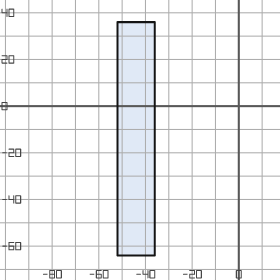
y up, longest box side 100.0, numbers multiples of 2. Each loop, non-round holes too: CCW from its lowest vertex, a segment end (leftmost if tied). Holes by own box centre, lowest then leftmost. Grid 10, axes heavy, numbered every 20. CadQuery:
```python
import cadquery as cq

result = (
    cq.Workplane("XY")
    .moveTo(-52.0, -64.0)
    .lineTo(-36.0, -64.0)
    .lineTo(-36.0, 36.0)
    .lineTo(-52.0, 36.0)
    .close()
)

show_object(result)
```